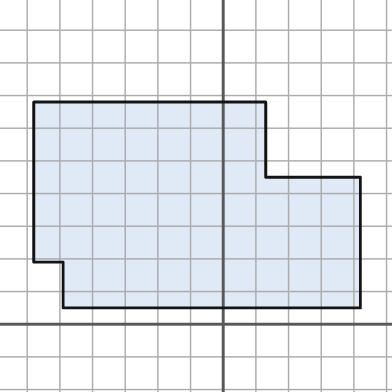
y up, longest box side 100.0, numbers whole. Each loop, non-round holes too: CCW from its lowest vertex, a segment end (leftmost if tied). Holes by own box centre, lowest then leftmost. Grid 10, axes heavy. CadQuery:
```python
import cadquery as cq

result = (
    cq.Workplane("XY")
    .moveTo(-49.0, 5.0)
    .lineTo(42.0, 5.0)
    .lineTo(42.0, 45.0)
    .lineTo(13.0, 45.0)
    .lineTo(13.0, 68.0)
    .lineTo(-58.0, 68.0)
    .lineTo(-58.0, 19.0)
    .lineTo(-49.0, 19.0)
    .close()
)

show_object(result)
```